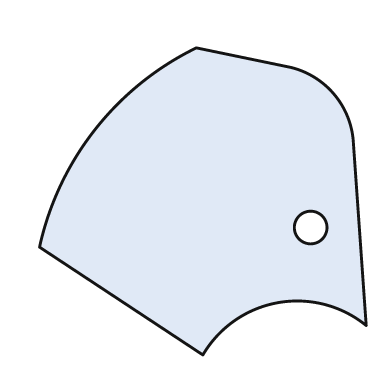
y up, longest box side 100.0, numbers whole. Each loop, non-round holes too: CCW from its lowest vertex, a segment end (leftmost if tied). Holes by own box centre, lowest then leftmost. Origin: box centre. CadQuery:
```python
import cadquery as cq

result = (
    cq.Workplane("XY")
    .moveTo(0.0, -47.0)
    .threePointArc((23.0, -31.0), (50.0, -38.0))
    .lineTo(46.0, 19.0)
    .threePointArc((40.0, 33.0), (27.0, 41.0))
    .lineTo(-2.0, 47.0)
    .threePointArc((-33.0, 22.0), (-50.0, -14.0))
    .close()
    .moveTo(33.0, -8.0)
    .circle(5.0)
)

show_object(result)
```